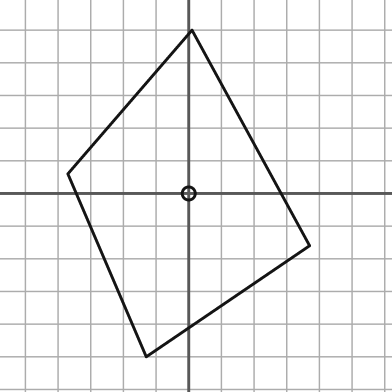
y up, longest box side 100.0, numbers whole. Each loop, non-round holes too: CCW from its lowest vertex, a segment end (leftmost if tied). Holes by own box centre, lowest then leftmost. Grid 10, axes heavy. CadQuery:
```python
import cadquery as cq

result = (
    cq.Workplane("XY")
    .moveTo(-13.0, -50.0)
    .lineTo(37.0, -16.0)
    .lineTo(1.0, 50.0)
    .lineTo(-37.0, 6.0)
    .close()
    .moveTo(0.0, 0.0)
    .circle(2.0)
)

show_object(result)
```